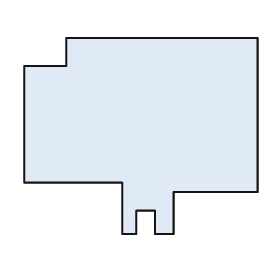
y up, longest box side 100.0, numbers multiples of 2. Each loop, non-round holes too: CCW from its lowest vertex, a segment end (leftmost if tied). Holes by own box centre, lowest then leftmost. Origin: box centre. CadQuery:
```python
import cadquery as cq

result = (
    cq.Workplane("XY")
    .moveTo(-8.0, -42.0)
    .lineTo(-2.0, -42.0)
    .lineTo(-2.0, -32.0)
    .lineTo(6.0, -32.0)
    .lineTo(6.0, -42.0)
    .lineTo(14.0, -42.0)
    .lineTo(14.0, -24.0)
    .lineTo(50.0, -24.0)
    .lineTo(50.0, 42.0)
    .lineTo(-32.0, 42.0)
    .lineTo(-32.0, 30.0)
    .lineTo(-50.0, 30.0)
    .lineTo(-50.0, -20.0)
    .lineTo(-8.0, -20.0)
    .close()
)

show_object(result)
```